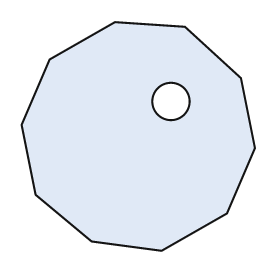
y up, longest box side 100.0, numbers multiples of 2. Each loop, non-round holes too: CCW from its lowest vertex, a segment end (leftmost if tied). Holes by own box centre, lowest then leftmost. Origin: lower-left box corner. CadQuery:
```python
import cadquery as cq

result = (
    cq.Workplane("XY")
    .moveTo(60.0, 0.0)
    .lineTo(88.0, 16.0)
    .lineTo(100.0, 44.0)
    .lineTo(94.0, 74.0)
    .lineTo(70.0, 96.0)
    .lineTo(40.0, 98.0)
    .lineTo(12.0, 82.0)
    .lineTo(0.0, 54.0)
    .lineTo(6.0, 24.0)
    .lineTo(30.0, 4.0)
    .close()
    .moveTo(64.0, 64.0)
    .circle(8.0)
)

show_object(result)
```